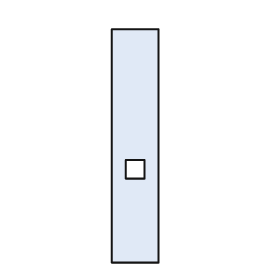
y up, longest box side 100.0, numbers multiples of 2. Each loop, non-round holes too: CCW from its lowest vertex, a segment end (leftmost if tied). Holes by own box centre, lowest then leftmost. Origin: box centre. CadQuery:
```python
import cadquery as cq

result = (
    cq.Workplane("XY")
    .moveTo(-10.0, -50.0)
    .lineTo(10.0, -50.0)
    .lineTo(10.0, 50.0)
    .lineTo(-10.0, 50.0)
    .close()
    .moveTo(-4.0, -14.0)
    .lineTo(4.0, -14.0)
    .lineTo(4.0, -6.0)
    .lineTo(-4.0, -6.0)
    .close()
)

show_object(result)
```